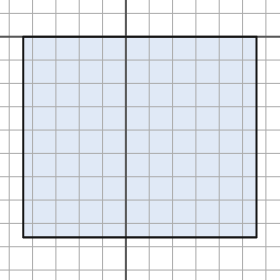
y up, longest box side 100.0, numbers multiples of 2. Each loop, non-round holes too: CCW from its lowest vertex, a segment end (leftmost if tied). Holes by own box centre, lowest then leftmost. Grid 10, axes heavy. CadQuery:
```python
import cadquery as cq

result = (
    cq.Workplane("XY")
    .moveTo(-44.0, -86.0)
    .lineTo(56.0, -86.0)
    .lineTo(56.0, 0.0)
    .lineTo(-44.0, 0.0)
    .close()
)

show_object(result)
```